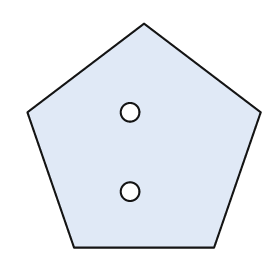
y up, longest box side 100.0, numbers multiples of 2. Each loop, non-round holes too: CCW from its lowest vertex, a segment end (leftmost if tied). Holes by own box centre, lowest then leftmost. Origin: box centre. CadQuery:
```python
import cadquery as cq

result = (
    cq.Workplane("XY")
    .moveTo(-30.0, -48.0)
    .lineTo(30.0, -48.0)
    .lineTo(50.0, 10.0)
    .lineTo(0.0, 48.0)
    .lineTo(-50.0, 10.0)
    .close()
    .moveTo(-6.0, -24.0)
    .circle(4.0)
    .moveTo(-6.0, 10.0)
    .circle(4.0)
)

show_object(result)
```